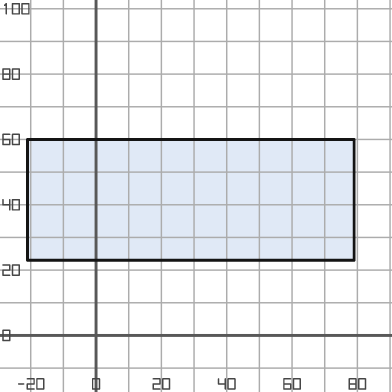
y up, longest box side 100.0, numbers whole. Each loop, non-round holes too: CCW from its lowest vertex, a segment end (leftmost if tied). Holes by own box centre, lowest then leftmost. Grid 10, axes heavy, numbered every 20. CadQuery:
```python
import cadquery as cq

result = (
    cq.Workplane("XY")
    .moveTo(-21.0, 23.0)
    .lineTo(79.0, 23.0)
    .lineTo(79.0, 60.0)
    .lineTo(-21.0, 60.0)
    .close()
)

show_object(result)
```